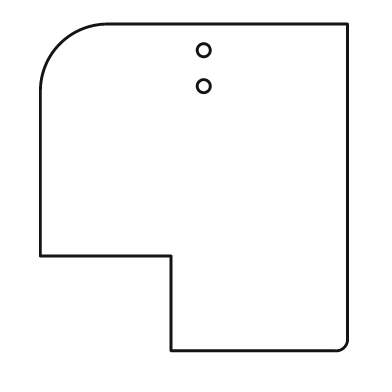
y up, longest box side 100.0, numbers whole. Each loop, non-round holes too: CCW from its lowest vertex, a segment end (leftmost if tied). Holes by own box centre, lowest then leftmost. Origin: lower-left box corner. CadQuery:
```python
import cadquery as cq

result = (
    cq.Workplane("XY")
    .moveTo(40.0, 0.0)
    .lineTo(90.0, 0.0)
    .threePointArc((93.0, 1.0), (94.0, 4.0))
    .lineTo(94.0, 100.0)
    .lineTo(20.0, 100.0)
    .threePointArc((6.0, 94.0), (0.0, 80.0))
    .lineTo(0.0, 29.0)
    .lineTo(40.0, 29.0)
    .close()
    .moveTo(50.0, 81.0)
    .circle(2.0)
    .moveTo(50.0, 92.0)
    .circle(2.0)
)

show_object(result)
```